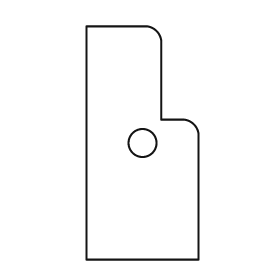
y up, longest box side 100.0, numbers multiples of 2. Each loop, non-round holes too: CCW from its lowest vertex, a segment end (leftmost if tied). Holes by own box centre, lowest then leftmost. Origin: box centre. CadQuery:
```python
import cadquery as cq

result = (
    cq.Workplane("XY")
    .moveTo(-24.0, -50.0)
    .lineTo(24.0, -50.0)
    .lineTo(24.0, 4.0)
    .threePointArc((22.0, 8.0), (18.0, 10.0))
    .lineTo(8.0, 10.0)
    .lineTo(8.0, 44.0)
    .threePointArc((6.0, 48.0), (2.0, 50.0))
    .lineTo(-24.0, 50.0)
    .close()
    .moveTo(0.0, 0.0)
    .circle(6.0)
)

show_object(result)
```